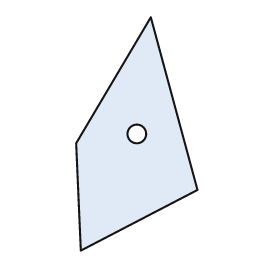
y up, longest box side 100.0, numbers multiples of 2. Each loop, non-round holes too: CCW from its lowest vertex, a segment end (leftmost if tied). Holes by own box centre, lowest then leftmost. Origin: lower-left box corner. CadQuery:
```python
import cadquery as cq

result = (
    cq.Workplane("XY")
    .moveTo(2.0, 0.0)
    .lineTo(52.0, 26.0)
    .lineTo(32.0, 100.0)
    .lineTo(0.0, 46.0)
    .close()
    .moveTo(26.0, 50.0)
    .circle(4.0)
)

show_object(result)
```